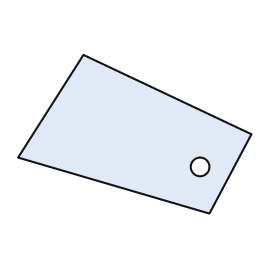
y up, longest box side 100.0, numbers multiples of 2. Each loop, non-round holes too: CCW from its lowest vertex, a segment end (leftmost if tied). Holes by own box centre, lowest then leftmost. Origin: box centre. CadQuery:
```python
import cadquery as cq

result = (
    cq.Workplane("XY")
    .moveTo(32.0, -34.0)
    .lineTo(50.0, 0.0)
    .lineTo(-22.0, 34.0)
    .lineTo(-50.0, -10.0)
    .close()
    .moveTo(28.0, -14.0)
    .circle(4.0)
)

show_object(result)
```